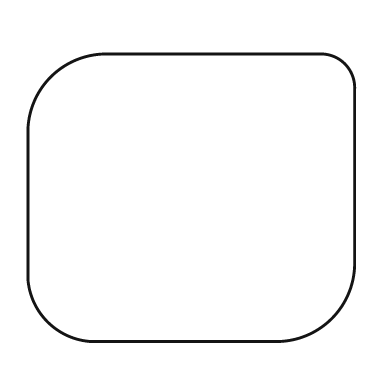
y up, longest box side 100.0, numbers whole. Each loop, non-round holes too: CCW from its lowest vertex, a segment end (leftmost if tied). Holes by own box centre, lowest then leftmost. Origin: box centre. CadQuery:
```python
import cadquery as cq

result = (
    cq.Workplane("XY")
    .moveTo(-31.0, -44.0)
    .lineTo(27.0, -44.0)
    .threePointArc((43.0, -37.0), (50.0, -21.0))
    .lineTo(50.0, 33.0)
    .threePointArc((47.0, 41.0), (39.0, 44.0))
    .lineTo(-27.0, 44.0)
    .threePointArc((-43.0, 37.0), (-50.0, 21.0))
    .lineTo(-50.0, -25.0)
    .threePointArc((-44.0, -38.0), (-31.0, -44.0))
    .close()
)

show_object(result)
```